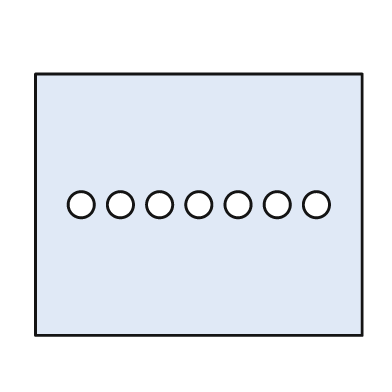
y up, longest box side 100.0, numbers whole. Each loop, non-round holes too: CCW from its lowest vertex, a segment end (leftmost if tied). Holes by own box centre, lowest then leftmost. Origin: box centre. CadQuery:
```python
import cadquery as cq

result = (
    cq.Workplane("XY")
    .moveTo(-50.0, -40.0)
    .lineTo(50.0, -40.0)
    .lineTo(50.0, 40.0)
    .lineTo(-50.0, 40.0)
    .close()
    .moveTo(-36.0, 0.0)
    .circle(4.0)
    .moveTo(-24.0, 0.0)
    .circle(4.0)
    .moveTo(-12.0, 0.0)
    .circle(4.0)
    .moveTo(0.0, 0.0)
    .circle(4.0)
    .moveTo(12.0, 0.0)
    .circle(4.0)
    .moveTo(24.0, 0.0)
    .circle(4.0)
    .moveTo(36.0, 0.0)
    .circle(4.0)
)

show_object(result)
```